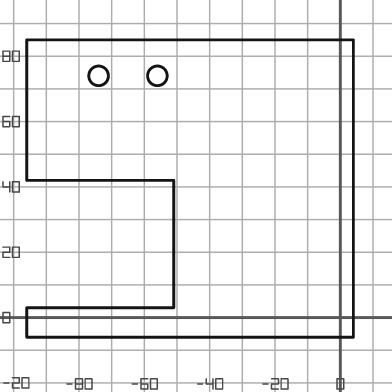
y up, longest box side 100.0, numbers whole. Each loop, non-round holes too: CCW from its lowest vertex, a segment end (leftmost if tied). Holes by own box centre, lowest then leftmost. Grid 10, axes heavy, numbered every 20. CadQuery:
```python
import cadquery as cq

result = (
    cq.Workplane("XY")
    .moveTo(-96.0, -6.0)
    .lineTo(4.0, -6.0)
    .lineTo(4.0, 85.0)
    .lineTo(-96.0, 85.0)
    .lineTo(-96.0, 42.0)
    .lineTo(-51.0, 42.0)
    .lineTo(-51.0, 3.0)
    .lineTo(-96.0, 3.0)
    .close()
    .moveTo(-74.0, 74.0)
    .circle(3.0)
    .moveTo(-56.0, 74.0)
    .circle(3.0)
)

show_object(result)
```